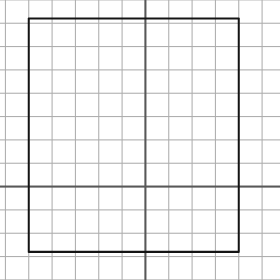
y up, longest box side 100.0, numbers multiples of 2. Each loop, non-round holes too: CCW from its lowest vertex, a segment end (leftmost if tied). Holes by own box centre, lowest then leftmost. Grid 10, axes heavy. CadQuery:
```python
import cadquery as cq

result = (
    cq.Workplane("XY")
    .moveTo(-50.0, -28.0)
    .lineTo(40.0, -28.0)
    .lineTo(40.0, 72.0)
    .lineTo(-50.0, 72.0)
    .close()
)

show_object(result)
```